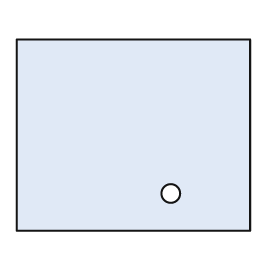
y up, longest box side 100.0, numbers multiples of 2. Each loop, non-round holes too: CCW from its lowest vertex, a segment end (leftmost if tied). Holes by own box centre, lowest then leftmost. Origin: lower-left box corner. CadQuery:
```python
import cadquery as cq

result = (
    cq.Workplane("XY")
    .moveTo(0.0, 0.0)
    .lineTo(100.0, 0.0)
    .lineTo(100.0, 82.0)
    .lineTo(0.0, 82.0)
    .close()
    .moveTo(66.0, 16.0)
    .circle(4.0)
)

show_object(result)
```